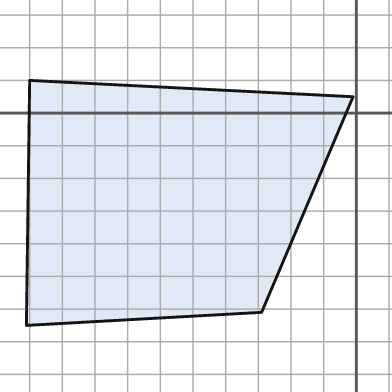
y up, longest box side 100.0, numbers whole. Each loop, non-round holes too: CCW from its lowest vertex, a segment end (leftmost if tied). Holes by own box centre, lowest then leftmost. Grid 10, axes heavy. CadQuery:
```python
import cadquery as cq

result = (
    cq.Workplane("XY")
    .moveTo(-101.0, -65.0)
    .lineTo(-29.0, -61.0)
    .lineTo(-1.0, 5.0)
    .lineTo(-100.0, 10.0)
    .close()
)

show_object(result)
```